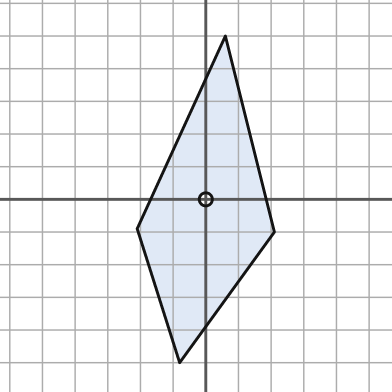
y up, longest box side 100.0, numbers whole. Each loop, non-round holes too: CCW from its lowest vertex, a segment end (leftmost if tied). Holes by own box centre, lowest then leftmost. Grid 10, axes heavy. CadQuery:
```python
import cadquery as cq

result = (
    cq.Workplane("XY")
    .moveTo(-8.0, -50.0)
    .lineTo(21.0, -10.0)
    .lineTo(6.0, 50.0)
    .lineTo(-21.0, -9.0)
    .close()
    .moveTo(0.0, 0.0)
    .circle(2.0)
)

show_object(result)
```